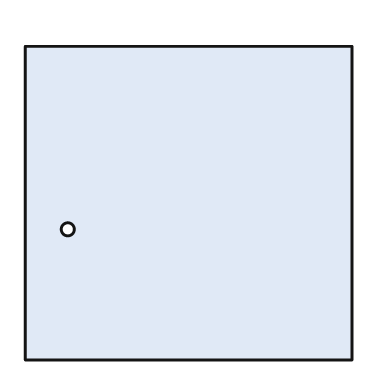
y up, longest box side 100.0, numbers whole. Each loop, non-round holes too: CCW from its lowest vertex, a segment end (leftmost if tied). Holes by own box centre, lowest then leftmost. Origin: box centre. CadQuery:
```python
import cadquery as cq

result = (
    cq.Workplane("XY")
    .moveTo(-50.0, -48.0)
    .lineTo(50.0, -48.0)
    .lineTo(50.0, 48.0)
    .lineTo(-50.0, 48.0)
    .close()
    .moveTo(-37.0, -8.0)
    .circle(2.0)
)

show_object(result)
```